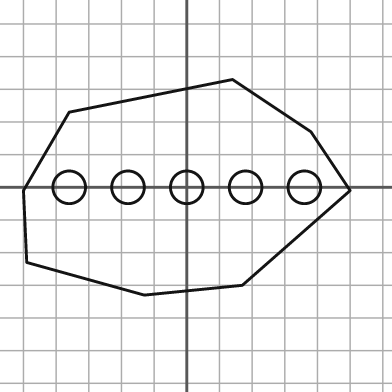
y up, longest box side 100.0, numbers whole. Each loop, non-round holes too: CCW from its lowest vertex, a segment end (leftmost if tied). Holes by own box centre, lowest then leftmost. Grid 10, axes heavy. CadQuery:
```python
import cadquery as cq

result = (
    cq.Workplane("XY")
    .moveTo(-13.0, -33.0)
    .lineTo(17.0, -30.0)
    .lineTo(50.0, -1.0)
    .lineTo(38.0, 17.0)
    .lineTo(14.0, 33.0)
    .lineTo(-36.0, 23.0)
    .lineTo(-50.0, -1.0)
    .lineTo(-49.0, -23.0)
    .close()
    .moveTo(-36.0, 0.0)
    .circle(5.0)
    .moveTo(-18.0, 0.0)
    .circle(5.0)
    .moveTo(0.0, 0.0)
    .circle(5.0)
    .moveTo(18.0, 0.0)
    .circle(5.0)
    .moveTo(36.0, 0.0)
    .circle(5.0)
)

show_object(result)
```